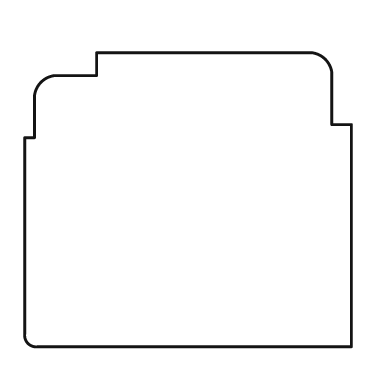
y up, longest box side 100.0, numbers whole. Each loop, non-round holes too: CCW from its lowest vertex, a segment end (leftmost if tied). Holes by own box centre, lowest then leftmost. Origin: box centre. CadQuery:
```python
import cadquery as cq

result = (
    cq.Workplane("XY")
    .moveTo(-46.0, -45.0)
    .lineTo(50.0, -45.0)
    .lineTo(50.0, 23.0)
    .lineTo(44.0, 23.0)
    .lineTo(44.0, 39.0)
    .threePointArc((42.0, 43.0), (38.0, 45.0))
    .lineTo(-28.0, 45.0)
    .lineTo(-28.0, 38.0)
    .lineTo(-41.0, 38.0)
    .threePointArc((-45.0, 36.0), (-47.0, 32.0))
    .lineTo(-47.0, 19.0)
    .lineTo(-50.0, 19.0)
    .lineTo(-50.0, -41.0)
    .threePointArc((-49.0, -44.0), (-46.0, -45.0))
    .close()
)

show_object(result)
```